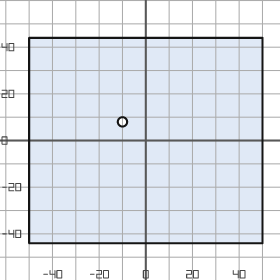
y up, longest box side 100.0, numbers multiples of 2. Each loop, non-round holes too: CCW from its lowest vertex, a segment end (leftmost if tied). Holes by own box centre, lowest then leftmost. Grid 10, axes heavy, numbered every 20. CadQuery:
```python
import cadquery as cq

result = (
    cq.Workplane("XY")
    .moveTo(-50.0, -44.0)
    .lineTo(50.0, -44.0)
    .lineTo(50.0, 44.0)
    .lineTo(-50.0, 44.0)
    .close()
    .moveTo(-10.0, 8.0)
    .circle(2.0)
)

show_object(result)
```